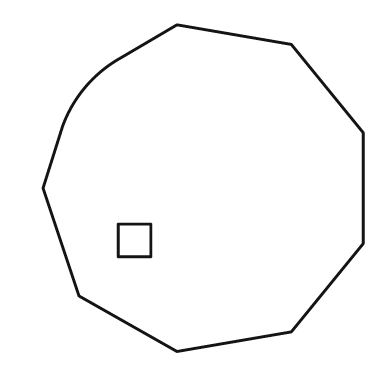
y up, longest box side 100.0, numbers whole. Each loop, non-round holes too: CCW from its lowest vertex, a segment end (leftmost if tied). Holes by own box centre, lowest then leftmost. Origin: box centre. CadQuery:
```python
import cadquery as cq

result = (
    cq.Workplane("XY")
    .moveTo(-8.0, -50.0)
    .lineTo(27.0, -44.0)
    .lineTo(49.0, -17.0)
    .lineTo(49.0, 17.0)
    .lineTo(27.0, 44.0)
    .lineTo(-8.0, 50.0)
    .lineTo(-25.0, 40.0)
    .threePointArc((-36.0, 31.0), (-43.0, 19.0))
    .lineTo(-49.0, 0.0)
    .lineTo(-38.0, -33.0)
    .close()
    .moveTo(-26.0, -21.0)
    .lineTo(-16.0, -21.0)
    .lineTo(-16.0, -11.0)
    .lineTo(-26.0, -11.0)
    .close()
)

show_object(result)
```